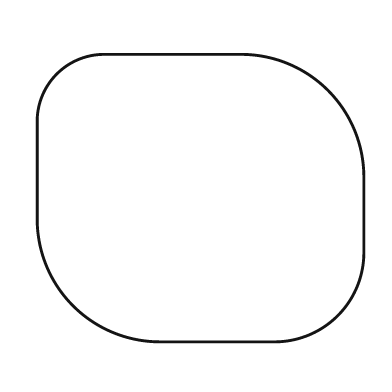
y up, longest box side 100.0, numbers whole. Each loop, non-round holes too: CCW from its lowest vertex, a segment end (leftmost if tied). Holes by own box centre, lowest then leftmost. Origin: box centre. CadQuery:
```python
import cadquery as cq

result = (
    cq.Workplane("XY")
    .moveTo(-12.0, -44.0)
    .lineTo(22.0, -44.0)
    .threePointArc((42.0, -36.0), (50.0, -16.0))
    .lineTo(50.0, 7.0)
    .threePointArc((39.0, 33.0), (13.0, 44.0))
    .lineTo(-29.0, 44.0)
    .threePointArc((-44.0, 38.0), (-50.0, 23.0))
    .lineTo(-50.0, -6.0)
    .threePointArc((-39.0, -33.0), (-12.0, -44.0))
    .close()
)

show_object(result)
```